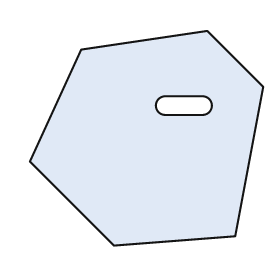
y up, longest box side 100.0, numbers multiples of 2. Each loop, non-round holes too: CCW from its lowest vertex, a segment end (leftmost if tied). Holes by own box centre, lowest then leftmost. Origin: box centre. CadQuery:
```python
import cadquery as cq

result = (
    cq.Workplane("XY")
    .moveTo(-14.0, -46.0)
    .lineTo(38.0, -42.0)
    .lineTo(50.0, 22.0)
    .lineTo(26.0, 46.0)
    .lineTo(-28.0, 38.0)
    .lineTo(-50.0, -10.0)
    .close()
    .moveTo(8.0, 10.0)
    .lineTo(24.0, 10.0)
    .threePointArc((28.0, 14.0), (24.0, 18.0))
    .lineTo(8.0, 18.0)
    .threePointArc((4.0, 14.0), (8.0, 10.0))
    .close()
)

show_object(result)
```